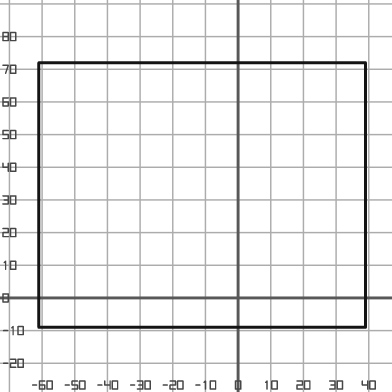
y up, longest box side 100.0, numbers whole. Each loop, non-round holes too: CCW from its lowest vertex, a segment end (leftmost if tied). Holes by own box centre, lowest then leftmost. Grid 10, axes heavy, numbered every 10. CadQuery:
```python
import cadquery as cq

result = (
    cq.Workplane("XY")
    .moveTo(-61.0, -9.0)
    .lineTo(39.0, -9.0)
    .lineTo(39.0, 72.0)
    .lineTo(-61.0, 72.0)
    .close()
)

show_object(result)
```